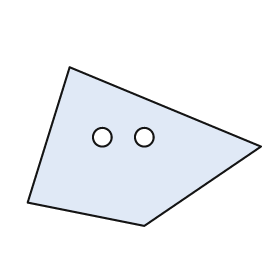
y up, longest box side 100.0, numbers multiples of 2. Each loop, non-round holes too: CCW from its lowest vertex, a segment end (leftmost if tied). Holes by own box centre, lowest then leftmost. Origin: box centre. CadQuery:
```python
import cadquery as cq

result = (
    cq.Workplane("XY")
    .moveTo(0.0, -34.0)
    .lineTo(50.0, 0.0)
    .lineTo(-32.0, 34.0)
    .lineTo(-50.0, -24.0)
    .close()
    .moveTo(-18.0, 4.0)
    .circle(4.0)
    .moveTo(0.0, 4.0)
    .circle(4.0)
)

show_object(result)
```